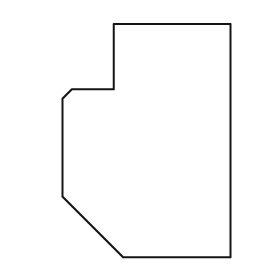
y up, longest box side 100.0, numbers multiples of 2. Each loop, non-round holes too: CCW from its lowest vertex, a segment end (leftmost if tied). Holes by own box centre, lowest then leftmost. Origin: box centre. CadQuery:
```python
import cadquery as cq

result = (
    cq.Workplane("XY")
    .moveTo(-10.0, -50.0)
    .lineTo(36.0, -50.0)
    .lineTo(36.0, 50.0)
    .lineTo(-14.0, 50.0)
    .lineTo(-14.0, 22.0)
    .lineTo(-32.0, 22.0)
    .lineTo(-36.0, 18.0)
    .lineTo(-36.0, -24.0)
    .close()
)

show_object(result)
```